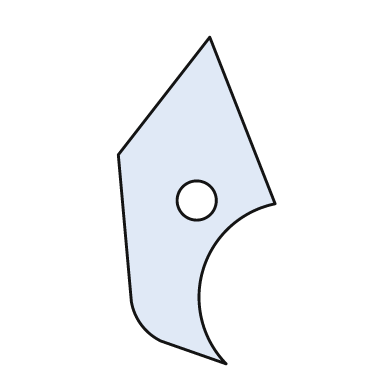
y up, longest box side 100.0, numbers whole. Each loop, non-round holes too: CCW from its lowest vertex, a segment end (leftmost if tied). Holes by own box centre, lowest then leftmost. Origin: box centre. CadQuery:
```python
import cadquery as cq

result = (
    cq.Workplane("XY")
    .moveTo(9.0, -50.0)
    .threePointArc((2.0, -21.0), (24.0, -1.0))
    .lineTo(4.0, 50.0)
    .lineTo(-24.0, 14.0)
    .lineTo(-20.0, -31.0)
    .threePointArc((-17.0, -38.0), (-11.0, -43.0))
    .close()
    .moveTo(0.0, 0.0)
    .circle(6.0)
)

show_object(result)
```